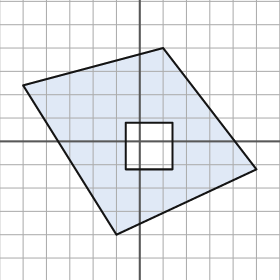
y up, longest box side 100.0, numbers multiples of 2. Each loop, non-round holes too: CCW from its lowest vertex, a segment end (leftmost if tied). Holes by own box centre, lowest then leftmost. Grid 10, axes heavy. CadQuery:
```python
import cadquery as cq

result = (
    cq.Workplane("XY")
    .moveTo(-10.0, -40.0)
    .lineTo(50.0, -12.0)
    .lineTo(10.0, 40.0)
    .lineTo(-50.0, 24.0)
    .close()
    .moveTo(-6.0, -12.0)
    .lineTo(14.0, -12.0)
    .lineTo(14.0, 8.0)
    .lineTo(-6.0, 8.0)
    .close()
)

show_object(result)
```